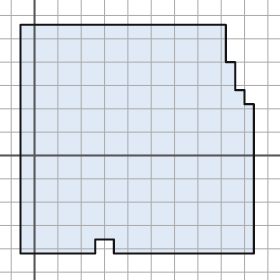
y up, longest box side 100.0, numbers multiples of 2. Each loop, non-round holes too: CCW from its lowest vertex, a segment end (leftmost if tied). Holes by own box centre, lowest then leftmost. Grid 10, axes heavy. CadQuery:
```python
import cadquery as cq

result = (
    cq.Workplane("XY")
    .moveTo(-6.0, -42.0)
    .lineTo(26.0, -42.0)
    .lineTo(26.0, -36.0)
    .lineTo(34.0, -36.0)
    .lineTo(34.0, -42.0)
    .lineTo(94.0, -42.0)
    .lineTo(94.0, 22.0)
    .lineTo(90.0, 22.0)
    .lineTo(90.0, 28.0)
    .lineTo(86.0, 28.0)
    .lineTo(86.0, 40.0)
    .lineTo(82.0, 40.0)
    .lineTo(82.0, 56.0)
    .lineTo(-6.0, 56.0)
    .close()
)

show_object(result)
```